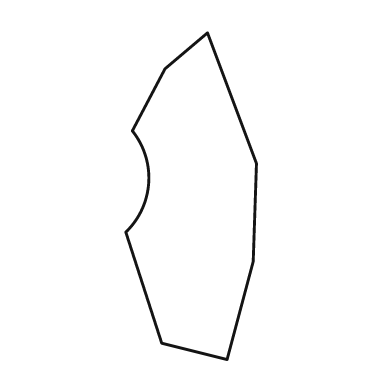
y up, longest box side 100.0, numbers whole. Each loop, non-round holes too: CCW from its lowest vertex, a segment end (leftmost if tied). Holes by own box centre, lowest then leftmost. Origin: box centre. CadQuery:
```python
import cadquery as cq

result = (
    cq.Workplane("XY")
    .moveTo(11.0, -50.0)
    .lineTo(19.0, -20.0)
    .lineTo(20.0, 10.0)
    .lineTo(5.0, 50.0)
    .lineTo(-8.0, 39.0)
    .lineTo(-18.0, 20.0)
    .threePointArc((-13.0, 4.0), (-20.0, -11.0))
    .lineTo(-9.0, -45.0)
    .close()
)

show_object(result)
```